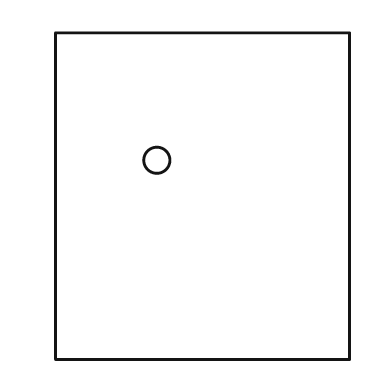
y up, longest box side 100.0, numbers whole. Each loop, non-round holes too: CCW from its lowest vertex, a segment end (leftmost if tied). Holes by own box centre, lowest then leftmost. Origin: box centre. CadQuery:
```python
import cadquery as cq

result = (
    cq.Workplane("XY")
    .moveTo(-45.0, -50.0)
    .lineTo(45.0, -50.0)
    .lineTo(45.0, 50.0)
    .lineTo(-45.0, 50.0)
    .close()
    .moveTo(-14.0, 11.0)
    .circle(4.0)
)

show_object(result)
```